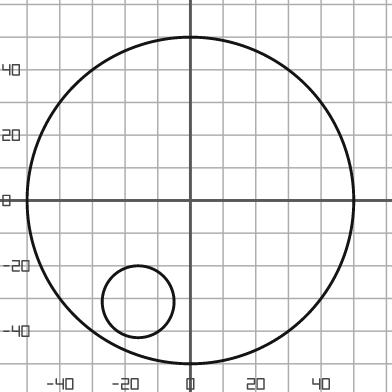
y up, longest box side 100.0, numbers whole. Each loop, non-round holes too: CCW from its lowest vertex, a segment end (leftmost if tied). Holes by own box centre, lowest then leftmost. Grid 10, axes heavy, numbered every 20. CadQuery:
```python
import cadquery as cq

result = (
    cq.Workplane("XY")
    .moveTo(0.0, 0.0)
    .circle(50.0)
    .moveTo(-16.0, -31.0)
    .circle(11.0)
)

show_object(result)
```